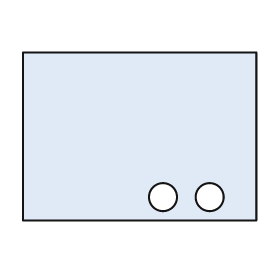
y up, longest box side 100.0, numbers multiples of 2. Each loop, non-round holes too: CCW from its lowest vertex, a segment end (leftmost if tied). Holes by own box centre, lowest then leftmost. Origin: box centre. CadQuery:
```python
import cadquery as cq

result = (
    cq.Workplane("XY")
    .moveTo(-50.0, -36.0)
    .lineTo(50.0, -36.0)
    .lineTo(50.0, 36.0)
    .lineTo(-50.0, 36.0)
    .close()
    .moveTo(10.0, -26.0)
    .circle(6.0)
    .moveTo(30.0, -26.0)
    .circle(6.0)
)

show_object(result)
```